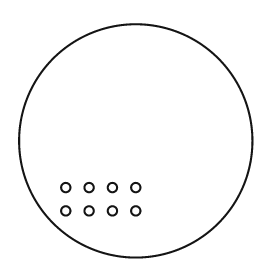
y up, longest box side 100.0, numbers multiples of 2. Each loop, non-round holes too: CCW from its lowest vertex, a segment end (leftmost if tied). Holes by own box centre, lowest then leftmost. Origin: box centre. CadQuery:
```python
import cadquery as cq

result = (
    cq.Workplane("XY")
    .moveTo(0.0, 0.0)
    .circle(50.0)
    .moveTo(-30.0, -30.0)
    .circle(2.0)
    .moveTo(-20.0, -30.0)
    .circle(2.0)
    .moveTo(-10.0, -30.0)
    .circle(2.0)
    .moveTo(0.0, -30.0)
    .circle(2.0)
    .moveTo(-30.0, -20.0)
    .circle(2.0)
    .moveTo(-20.0, -20.0)
    .circle(2.0)
    .moveTo(-10.0, -20.0)
    .circle(2.0)
    .moveTo(0.0, -20.0)
    .circle(2.0)
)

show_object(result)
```